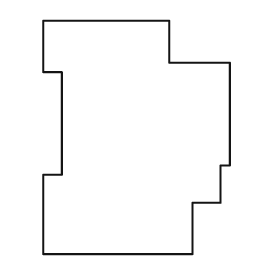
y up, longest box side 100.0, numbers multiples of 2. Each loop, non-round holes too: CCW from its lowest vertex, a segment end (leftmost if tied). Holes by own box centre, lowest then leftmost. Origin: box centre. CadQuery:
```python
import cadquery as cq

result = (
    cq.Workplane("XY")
    .moveTo(-40.0, -50.0)
    .lineTo(24.0, -50.0)
    .lineTo(24.0, -28.0)
    .lineTo(36.0, -28.0)
    .lineTo(36.0, -12.0)
    .lineTo(40.0, -12.0)
    .lineTo(40.0, 32.0)
    .lineTo(14.0, 32.0)
    .lineTo(14.0, 50.0)
    .lineTo(-40.0, 50.0)
    .lineTo(-40.0, 28.0)
    .lineTo(-32.0, 28.0)
    .lineTo(-32.0, -16.0)
    .lineTo(-40.0, -16.0)
    .close()
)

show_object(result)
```